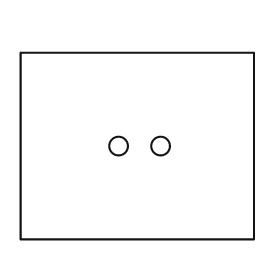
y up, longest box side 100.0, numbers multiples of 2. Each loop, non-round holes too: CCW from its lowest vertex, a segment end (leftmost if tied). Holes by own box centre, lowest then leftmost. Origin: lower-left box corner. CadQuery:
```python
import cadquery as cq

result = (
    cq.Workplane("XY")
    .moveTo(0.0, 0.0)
    .lineTo(100.0, 0.0)
    .lineTo(100.0, 80.0)
    .lineTo(0.0, 80.0)
    .close()
    .moveTo(42.0, 40.0)
    .circle(4.0)
    .moveTo(60.0, 40.0)
    .circle(4.0)
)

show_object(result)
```